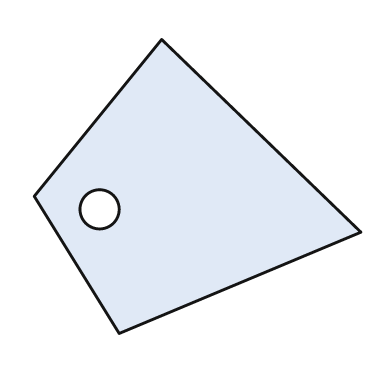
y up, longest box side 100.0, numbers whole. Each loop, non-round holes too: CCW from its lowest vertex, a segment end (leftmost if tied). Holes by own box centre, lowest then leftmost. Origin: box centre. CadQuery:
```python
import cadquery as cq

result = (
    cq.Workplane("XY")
    .moveTo(-24.0, -45.0)
    .lineTo(50.0, -14.0)
    .lineTo(-11.0, 45.0)
    .lineTo(-50.0, -3.0)
    .close()
    .moveTo(-30.0, -7.0)
    .circle(6.0)
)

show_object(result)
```